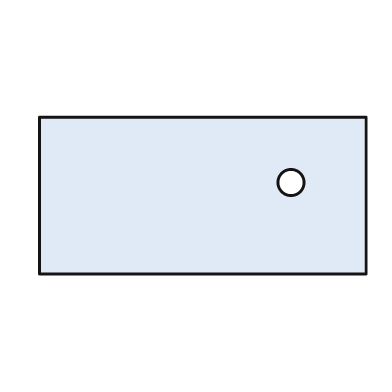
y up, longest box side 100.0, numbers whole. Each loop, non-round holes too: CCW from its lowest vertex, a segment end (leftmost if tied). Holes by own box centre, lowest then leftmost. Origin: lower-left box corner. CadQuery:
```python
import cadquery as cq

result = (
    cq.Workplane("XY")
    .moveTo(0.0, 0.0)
    .lineTo(100.0, 0.0)
    .lineTo(100.0, 48.0)
    .lineTo(0.0, 48.0)
    .close()
    .moveTo(77.0, 28.0)
    .circle(4.0)
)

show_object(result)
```